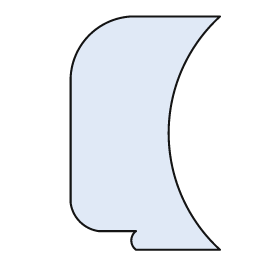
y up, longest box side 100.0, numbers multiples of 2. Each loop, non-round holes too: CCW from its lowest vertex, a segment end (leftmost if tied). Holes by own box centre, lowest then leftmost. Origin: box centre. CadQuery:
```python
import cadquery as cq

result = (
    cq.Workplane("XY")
    .moveTo(-4.0, -50.0)
    .lineTo(32.0, -50.0)
    .threePointArc((10.0, 0.0), (32.0, 50.0))
    .lineTo(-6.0, 50.0)
    .threePointArc((-24.0, 42.0), (-32.0, 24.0))
    .lineTo(-32.0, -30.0)
    .threePointArc((-28.0, -38.0), (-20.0, -42.0))
    .lineTo(-4.0, -42.0)
    .threePointArc((-6.0, -46.0), (-4.0, -50.0))
    .close()
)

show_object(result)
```